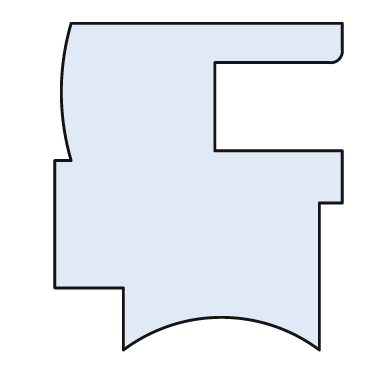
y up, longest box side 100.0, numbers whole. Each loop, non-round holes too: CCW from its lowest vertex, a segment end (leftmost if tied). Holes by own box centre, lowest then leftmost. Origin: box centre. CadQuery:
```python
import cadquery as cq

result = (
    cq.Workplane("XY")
    .moveTo(-23.0, -50.0)
    .threePointArc((7.0, -40.0), (37.0, -50.0))
    .lineTo(37.0, -5.0)
    .lineTo(44.0, -5.0)
    .lineTo(44.0, 11.0)
    .lineTo(5.0, 11.0)
    .lineTo(5.0, 38.0)
    .lineTo(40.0, 38.0)
    .threePointArc((43.0, 39.0), (44.0, 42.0))
    .lineTo(44.0, 50.0)
    .lineTo(-39.0, 50.0)
    .threePointArc((-42.0, 29.0), (-39.0, 8.0))
    .lineTo(-44.0, 8.0)
    .lineTo(-44.0, -31.0)
    .lineTo(-23.0, -31.0)
    .close()
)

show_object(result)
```